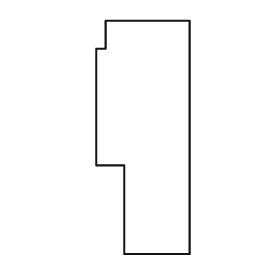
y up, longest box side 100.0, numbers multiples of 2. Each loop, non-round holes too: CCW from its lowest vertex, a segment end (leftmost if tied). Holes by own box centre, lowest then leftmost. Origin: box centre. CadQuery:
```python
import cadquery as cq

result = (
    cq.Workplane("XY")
    .moveTo(-8.0, -50.0)
    .lineTo(20.0, -50.0)
    .lineTo(20.0, 50.0)
    .lineTo(-16.0, 50.0)
    .lineTo(-16.0, 38.0)
    .lineTo(-20.0, 38.0)
    .lineTo(-20.0, -12.0)
    .lineTo(-8.0, -12.0)
    .close()
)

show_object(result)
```